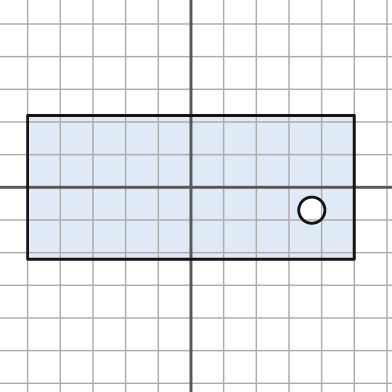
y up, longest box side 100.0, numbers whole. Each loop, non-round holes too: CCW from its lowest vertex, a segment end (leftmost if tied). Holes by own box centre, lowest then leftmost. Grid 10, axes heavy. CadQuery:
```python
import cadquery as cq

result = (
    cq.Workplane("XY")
    .moveTo(-50.0, -22.0)
    .lineTo(50.0, -22.0)
    .lineTo(50.0, 22.0)
    .lineTo(-50.0, 22.0)
    .close()
    .moveTo(37.0, -7.0)
    .circle(4.0)
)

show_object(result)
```